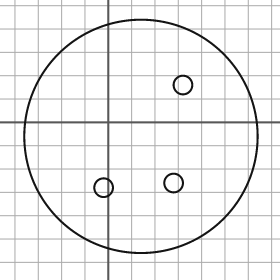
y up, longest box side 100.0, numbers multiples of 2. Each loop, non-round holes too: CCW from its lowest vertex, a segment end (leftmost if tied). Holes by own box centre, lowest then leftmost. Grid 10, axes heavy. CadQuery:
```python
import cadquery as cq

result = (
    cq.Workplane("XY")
    .moveTo(14.0, -6.0)
    .circle(50.0)
    .moveTo(-2.0, -28.0)
    .circle(4.0)
    .moveTo(28.0, -26.0)
    .circle(4.0)
    .moveTo(32.0, 16.0)
    .circle(4.0)
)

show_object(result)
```